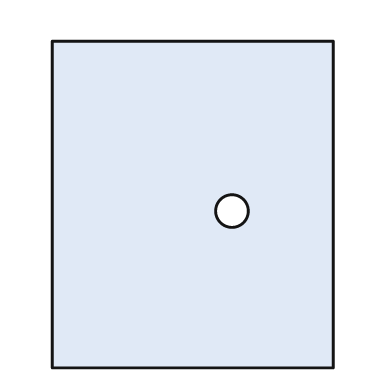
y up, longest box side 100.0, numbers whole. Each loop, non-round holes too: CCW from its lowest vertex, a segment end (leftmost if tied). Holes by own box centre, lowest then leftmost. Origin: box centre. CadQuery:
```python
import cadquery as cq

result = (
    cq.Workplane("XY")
    .moveTo(-43.0, -50.0)
    .lineTo(43.0, -50.0)
    .lineTo(43.0, 50.0)
    .lineTo(-43.0, 50.0)
    .close()
    .moveTo(12.0, -2.0)
    .circle(5.0)
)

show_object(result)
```